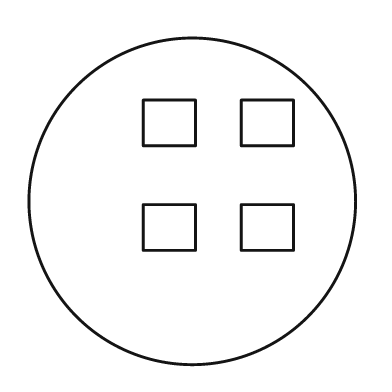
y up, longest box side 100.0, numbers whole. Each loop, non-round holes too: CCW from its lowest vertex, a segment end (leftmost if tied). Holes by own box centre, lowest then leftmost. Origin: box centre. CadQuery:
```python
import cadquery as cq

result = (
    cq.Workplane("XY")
    .moveTo(0.0, 0.0)
    .circle(50.0)
    .moveTo(-15.0, -15.0)
    .lineTo(1.0, -15.0)
    .lineTo(1.0, -1.0)
    .lineTo(-15.0, -1.0)
    .close()
    .moveTo(15.0, -15.0)
    .lineTo(31.0, -15.0)
    .lineTo(31.0, -1.0)
    .lineTo(15.0, -1.0)
    .close()
    .moveTo(-15.0, 17.0)
    .lineTo(1.0, 17.0)
    .lineTo(1.0, 31.0)
    .lineTo(-15.0, 31.0)
    .close()
    .moveTo(15.0, 17.0)
    .lineTo(31.0, 17.0)
    .lineTo(31.0, 31.0)
    .lineTo(15.0, 31.0)
    .close()
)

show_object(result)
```